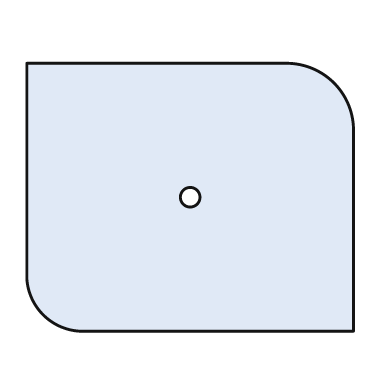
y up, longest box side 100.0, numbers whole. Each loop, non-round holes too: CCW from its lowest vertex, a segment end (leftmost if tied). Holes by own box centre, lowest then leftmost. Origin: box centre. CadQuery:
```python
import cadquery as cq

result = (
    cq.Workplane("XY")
    .moveTo(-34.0, -41.0)
    .lineTo(50.0, -41.0)
    .lineTo(50.0, 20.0)
    .threePointArc((44.0, 35.0), (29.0, 41.0))
    .lineTo(-50.0, 41.0)
    .lineTo(-50.0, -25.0)
    .threePointArc((-45.0, -36.0), (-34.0, -41.0))
    .close()
    .moveTo(0.0, 0.0)
    .circle(3.0)
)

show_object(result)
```